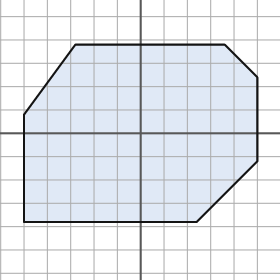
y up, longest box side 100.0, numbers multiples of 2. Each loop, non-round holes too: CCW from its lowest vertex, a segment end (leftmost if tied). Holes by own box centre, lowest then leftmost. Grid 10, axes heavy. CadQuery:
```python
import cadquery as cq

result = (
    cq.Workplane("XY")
    .moveTo(-50.0, -38.0)
    .lineTo(24.0, -38.0)
    .lineTo(50.0, -12.0)
    .lineTo(50.0, 24.0)
    .lineTo(36.0, 38.0)
    .lineTo(-28.0, 38.0)
    .lineTo(-50.0, 8.0)
    .close()
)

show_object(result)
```